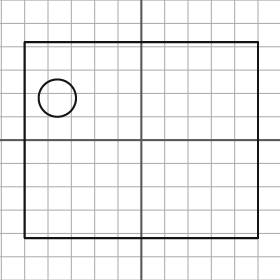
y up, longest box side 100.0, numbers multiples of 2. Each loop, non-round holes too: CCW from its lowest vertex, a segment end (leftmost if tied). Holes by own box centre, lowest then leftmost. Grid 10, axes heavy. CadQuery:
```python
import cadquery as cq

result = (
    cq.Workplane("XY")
    .moveTo(-50.0, -42.0)
    .lineTo(50.0, -42.0)
    .lineTo(50.0, 42.0)
    .lineTo(-50.0, 42.0)
    .close()
    .moveTo(-36.0, 18.0)
    .circle(8.0)
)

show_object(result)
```